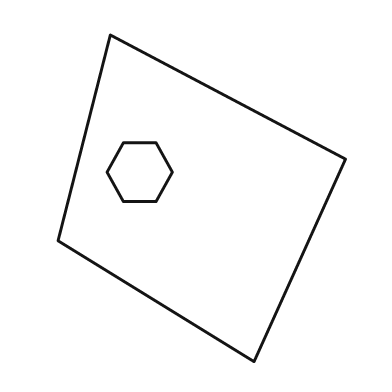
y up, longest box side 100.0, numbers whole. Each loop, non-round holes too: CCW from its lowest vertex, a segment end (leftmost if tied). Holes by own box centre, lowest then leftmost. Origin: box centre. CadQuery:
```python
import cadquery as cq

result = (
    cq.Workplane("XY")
    .moveTo(16.0, -50.0)
    .lineTo(44.0, 12.0)
    .lineTo(-28.0, 50.0)
    .lineTo(-44.0, -13.0)
    .close()
    .moveTo(-24.0, -1.0)
    .lineTo(-14.0, -1.0)
    .lineTo(-9.0, 8.0)
    .lineTo(-14.0, 17.0)
    .lineTo(-24.0, 17.0)
    .lineTo(-29.0, 8.0)
    .close()
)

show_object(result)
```